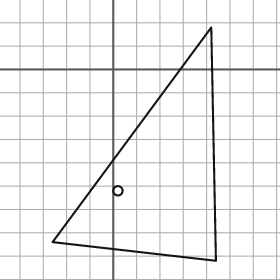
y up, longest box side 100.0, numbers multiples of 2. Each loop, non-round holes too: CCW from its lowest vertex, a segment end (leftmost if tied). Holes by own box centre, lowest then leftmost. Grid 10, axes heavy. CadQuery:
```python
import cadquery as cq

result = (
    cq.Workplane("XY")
    .moveTo(44.0, -82.0)
    .lineTo(42.0, 18.0)
    .lineTo(-26.0, -74.0)
    .close()
    .moveTo(2.0, -52.0)
    .circle(2.0)
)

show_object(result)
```